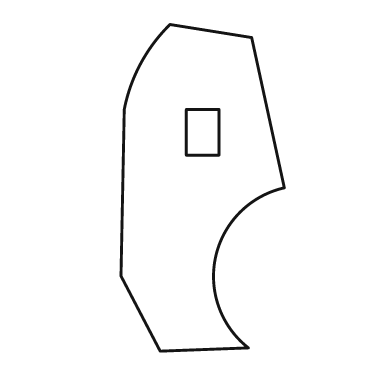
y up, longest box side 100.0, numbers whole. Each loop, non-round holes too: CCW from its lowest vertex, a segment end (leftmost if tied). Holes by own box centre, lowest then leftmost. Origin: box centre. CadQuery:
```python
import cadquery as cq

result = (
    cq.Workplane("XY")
    .moveTo(-13.0, -50.0)
    .lineTo(14.0, -49.0)
    .threePointArc((4.0, -21.0), (25.0, 0.0))
    .lineTo(15.0, 46.0)
    .lineTo(-10.0, 50.0)
    .threePointArc((-19.0, 38.0), (-24.0, 24.0))
    .lineTo(-25.0, -27.0)
    .close()
    .moveTo(-5.0, 10.0)
    .lineTo(5.0, 10.0)
    .lineTo(5.0, 24.0)
    .lineTo(-5.0, 24.0)
    .close()
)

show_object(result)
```